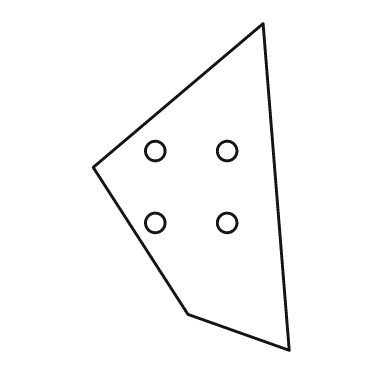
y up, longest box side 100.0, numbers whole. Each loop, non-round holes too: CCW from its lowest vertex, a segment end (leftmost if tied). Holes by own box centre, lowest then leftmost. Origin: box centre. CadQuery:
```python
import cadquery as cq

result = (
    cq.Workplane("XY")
    .moveTo(30.0, -50.0)
    .lineTo(22.0, 50.0)
    .lineTo(-30.0, 6.0)
    .lineTo(-1.0, -39.0)
    .close()
    .moveTo(-11.0, -11.0)
    .circle(3.0)
    .moveTo(11.0, -11.0)
    .circle(3.0)
    .moveTo(-11.0, 11.0)
    .circle(3.0)
    .moveTo(11.0, 11.0)
    .circle(3.0)
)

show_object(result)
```